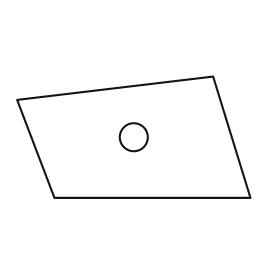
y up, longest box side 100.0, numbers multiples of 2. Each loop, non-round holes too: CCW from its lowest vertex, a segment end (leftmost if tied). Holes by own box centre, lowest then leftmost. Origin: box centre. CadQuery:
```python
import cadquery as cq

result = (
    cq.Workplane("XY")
    .moveTo(-34.0, -26.0)
    .lineTo(50.0, -26.0)
    .lineTo(34.0, 26.0)
    .lineTo(-50.0, 16.0)
    .close()
    .moveTo(0.0, 0.0)
    .circle(6.0)
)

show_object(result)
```